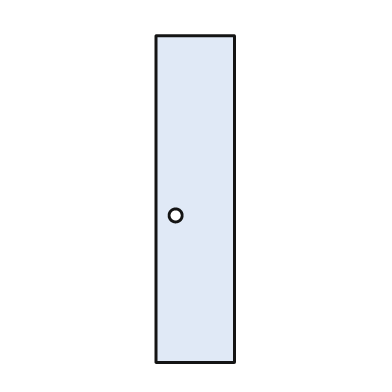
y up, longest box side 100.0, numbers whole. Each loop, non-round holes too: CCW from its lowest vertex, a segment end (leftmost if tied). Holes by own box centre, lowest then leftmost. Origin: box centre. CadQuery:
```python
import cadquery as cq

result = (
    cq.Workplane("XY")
    .moveTo(-12.0, -50.0)
    .lineTo(12.0, -50.0)
    .lineTo(12.0, 50.0)
    .lineTo(-12.0, 50.0)
    .close()
    .moveTo(-6.0, -5.0)
    .circle(2.0)
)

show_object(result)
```